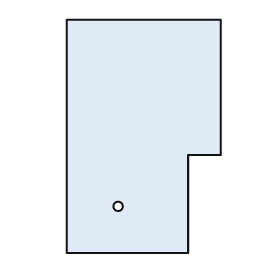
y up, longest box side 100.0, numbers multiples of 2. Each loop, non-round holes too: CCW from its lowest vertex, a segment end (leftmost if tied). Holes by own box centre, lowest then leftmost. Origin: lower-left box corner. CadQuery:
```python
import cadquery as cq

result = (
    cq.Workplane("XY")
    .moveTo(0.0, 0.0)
    .lineTo(52.0, 0.0)
    .lineTo(52.0, 42.0)
    .lineTo(66.0, 42.0)
    .lineTo(66.0, 100.0)
    .lineTo(0.0, 100.0)
    .close()
    .moveTo(22.0, 20.0)
    .circle(2.0)
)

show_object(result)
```